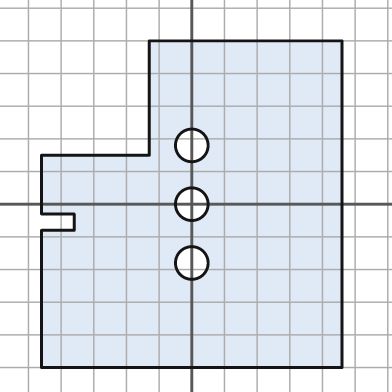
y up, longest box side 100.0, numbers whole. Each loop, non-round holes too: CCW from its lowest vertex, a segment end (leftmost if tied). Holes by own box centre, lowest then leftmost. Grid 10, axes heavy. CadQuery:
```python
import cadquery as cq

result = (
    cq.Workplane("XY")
    .moveTo(-46.0, -50.0)
    .lineTo(46.0, -50.0)
    .lineTo(46.0, 50.0)
    .lineTo(-13.0, 50.0)
    .lineTo(-13.0, 15.0)
    .lineTo(-46.0, 15.0)
    .lineTo(-46.0, -3.0)
    .lineTo(-36.0, -3.0)
    .lineTo(-36.0, -8.0)
    .lineTo(-46.0, -8.0)
    .close()
    .moveTo(0.0, -18.0)
    .circle(5.0)
    .moveTo(0.0, 0.0)
    .circle(5.0)
    .moveTo(0.0, 18.0)
    .circle(5.0)
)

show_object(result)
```